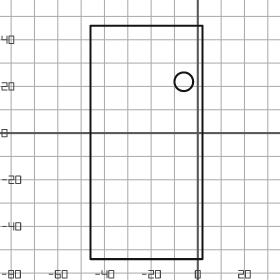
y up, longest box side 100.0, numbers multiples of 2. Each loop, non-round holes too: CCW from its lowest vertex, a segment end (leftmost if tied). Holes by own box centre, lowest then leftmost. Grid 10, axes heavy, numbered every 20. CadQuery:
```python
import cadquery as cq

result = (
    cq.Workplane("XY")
    .moveTo(-46.0, -54.0)
    .lineTo(2.0, -54.0)
    .lineTo(2.0, 46.0)
    .lineTo(-46.0, 46.0)
    .close()
    .moveTo(-6.0, 22.0)
    .circle(4.0)
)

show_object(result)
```